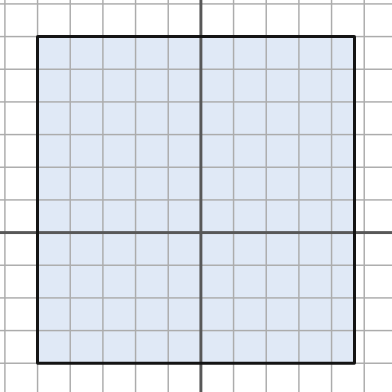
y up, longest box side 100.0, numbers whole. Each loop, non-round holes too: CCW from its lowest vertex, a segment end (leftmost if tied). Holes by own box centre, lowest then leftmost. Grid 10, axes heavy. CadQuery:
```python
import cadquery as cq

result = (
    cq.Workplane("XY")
    .moveTo(-50.0, -40.0)
    .lineTo(47.0, -40.0)
    .lineTo(47.0, 60.0)
    .lineTo(-50.0, 60.0)
    .close()
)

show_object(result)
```